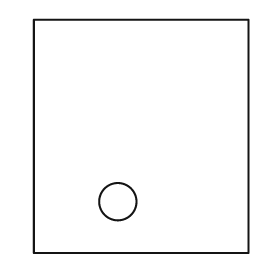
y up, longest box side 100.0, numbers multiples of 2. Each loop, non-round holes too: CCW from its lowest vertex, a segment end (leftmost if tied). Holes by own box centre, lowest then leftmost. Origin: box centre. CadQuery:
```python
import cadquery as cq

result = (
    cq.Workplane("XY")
    .moveTo(-46.0, -50.0)
    .lineTo(46.0, -50.0)
    .lineTo(46.0, 50.0)
    .lineTo(-46.0, 50.0)
    .close()
    .moveTo(-10.0, -28.0)
    .circle(8.0)
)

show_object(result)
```